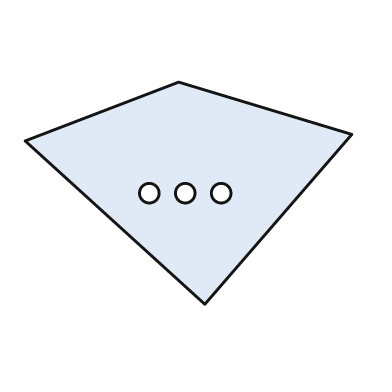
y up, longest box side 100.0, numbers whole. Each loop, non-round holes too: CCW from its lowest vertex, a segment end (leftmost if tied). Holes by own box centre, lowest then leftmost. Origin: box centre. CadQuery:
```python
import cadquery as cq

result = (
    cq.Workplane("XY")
    .moveTo(5.0, -34.0)
    .lineTo(50.0, 18.0)
    .lineTo(-3.0, 34.0)
    .lineTo(-50.0, 16.0)
    .close()
    .moveTo(-12.0, 0.0)
    .circle(3.0)
    .moveTo(-1.0, 0.0)
    .circle(3.0)
    .moveTo(10.0, 0.0)
    .circle(3.0)
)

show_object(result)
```